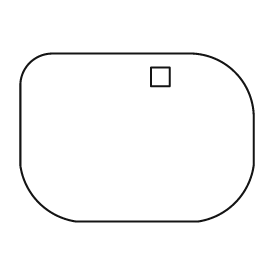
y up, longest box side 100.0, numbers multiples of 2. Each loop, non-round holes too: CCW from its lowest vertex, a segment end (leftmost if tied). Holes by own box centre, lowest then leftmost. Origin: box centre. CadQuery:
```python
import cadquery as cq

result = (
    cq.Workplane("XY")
    .moveTo(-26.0, -36.0)
    .lineTo(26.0, -36.0)
    .threePointArc((42.0, -28.0), (50.0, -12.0))
    .lineTo(50.0, 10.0)
    .threePointArc((42.0, 28.0), (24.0, 36.0))
    .lineTo(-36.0, 36.0)
    .threePointArc((-46.0, 32.0), (-50.0, 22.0))
    .lineTo(-50.0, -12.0)
    .threePointArc((-42.0, -28.0), (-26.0, -36.0))
    .close()
    .moveTo(6.0, 22.0)
    .lineTo(14.0, 22.0)
    .lineTo(14.0, 30.0)
    .lineTo(6.0, 30.0)
    .close()
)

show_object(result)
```